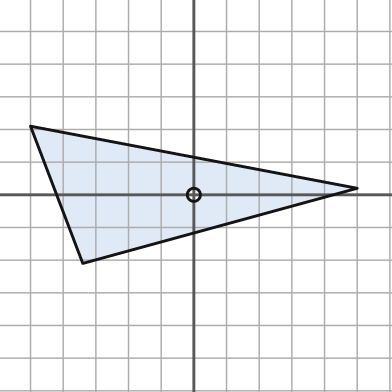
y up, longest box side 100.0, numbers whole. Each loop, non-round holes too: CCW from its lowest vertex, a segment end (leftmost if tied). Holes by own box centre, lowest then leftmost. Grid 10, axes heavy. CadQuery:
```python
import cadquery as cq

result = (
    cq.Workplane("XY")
    .moveTo(-34.0, -21.0)
    .lineTo(50.0, 2.0)
    .lineTo(-50.0, 21.0)
    .close()
    .moveTo(0.0, 0.0)
    .circle(2.0)
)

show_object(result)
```